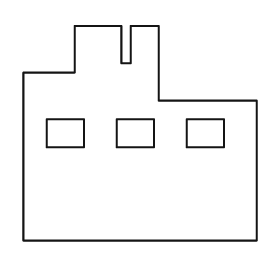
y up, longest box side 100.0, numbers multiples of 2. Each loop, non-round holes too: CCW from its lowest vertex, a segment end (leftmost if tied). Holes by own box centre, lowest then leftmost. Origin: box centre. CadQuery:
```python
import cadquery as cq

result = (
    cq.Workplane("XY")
    .moveTo(-50.0, -46.0)
    .lineTo(50.0, -46.0)
    .lineTo(50.0, 14.0)
    .lineTo(8.0, 14.0)
    .lineTo(8.0, 46.0)
    .lineTo(-4.0, 46.0)
    .lineTo(-4.0, 30.0)
    .lineTo(-8.0, 30.0)
    .lineTo(-8.0, 46.0)
    .lineTo(-28.0, 46.0)
    .lineTo(-28.0, 26.0)
    .lineTo(-50.0, 26.0)
    .close()
    .moveTo(-40.0, -6.0)
    .lineTo(-24.0, -6.0)
    .lineTo(-24.0, 6.0)
    .lineTo(-40.0, 6.0)
    .close()
    .moveTo(-10.0, -6.0)
    .lineTo(6.0, -6.0)
    .lineTo(6.0, 6.0)
    .lineTo(-10.0, 6.0)
    .close()
    .moveTo(20.0, -6.0)
    .lineTo(36.0, -6.0)
    .lineTo(36.0, 6.0)
    .lineTo(20.0, 6.0)
    .close()
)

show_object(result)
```